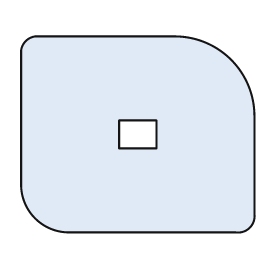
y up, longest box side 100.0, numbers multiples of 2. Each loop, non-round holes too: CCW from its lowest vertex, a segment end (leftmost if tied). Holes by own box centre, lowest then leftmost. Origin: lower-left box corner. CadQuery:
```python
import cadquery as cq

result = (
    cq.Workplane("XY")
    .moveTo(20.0, 0.0)
    .lineTo(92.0, 0.0)
    .threePointArc((98.0, 2.0), (100.0, 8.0))
    .lineTo(100.0, 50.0)
    .threePointArc((90.0, 74.0), (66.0, 84.0))
    .lineTo(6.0, 84.0)
    .threePointArc((2.0, 82.0), (0.0, 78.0))
    .lineTo(0.0, 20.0)
    .threePointArc((6.0, 6.0), (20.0, 0.0))
    .close()
    .moveTo(42.0, 36.0)
    .lineTo(58.0, 36.0)
    .lineTo(58.0, 48.0)
    .lineTo(42.0, 48.0)
    .close()
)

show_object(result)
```